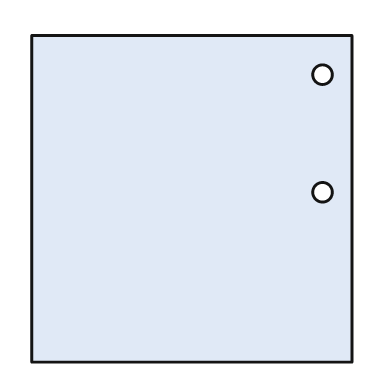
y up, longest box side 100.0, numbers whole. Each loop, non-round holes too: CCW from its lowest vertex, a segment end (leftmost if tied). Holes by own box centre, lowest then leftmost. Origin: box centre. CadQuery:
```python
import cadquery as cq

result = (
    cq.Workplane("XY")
    .moveTo(-49.0, -50.0)
    .lineTo(49.0, -50.0)
    .lineTo(49.0, 50.0)
    .lineTo(-49.0, 50.0)
    .close()
    .moveTo(40.0, 2.0)
    .circle(3.0)
    .moveTo(40.0, 38.0)
    .circle(3.0)
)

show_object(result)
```